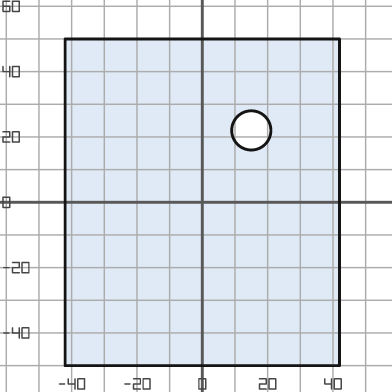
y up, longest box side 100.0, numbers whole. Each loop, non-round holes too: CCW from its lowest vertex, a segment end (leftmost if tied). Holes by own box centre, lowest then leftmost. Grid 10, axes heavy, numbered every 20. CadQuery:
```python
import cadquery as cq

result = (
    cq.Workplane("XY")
    .moveTo(-42.0, -50.0)
    .lineTo(42.0, -50.0)
    .lineTo(42.0, 50.0)
    .lineTo(-42.0, 50.0)
    .close()
    .moveTo(15.0, 22.0)
    .circle(6.0)
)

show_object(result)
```